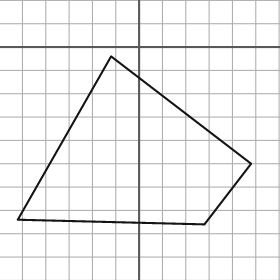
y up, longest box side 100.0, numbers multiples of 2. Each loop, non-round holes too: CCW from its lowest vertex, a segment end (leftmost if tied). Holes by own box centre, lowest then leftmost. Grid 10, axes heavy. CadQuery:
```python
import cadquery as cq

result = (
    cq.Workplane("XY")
    .moveTo(28.0, -76.0)
    .lineTo(48.0, -50.0)
    .lineTo(-12.0, -4.0)
    .lineTo(-52.0, -74.0)
    .close()
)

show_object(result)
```